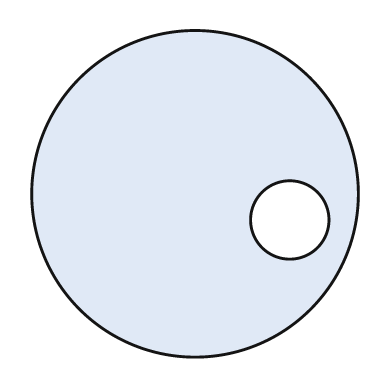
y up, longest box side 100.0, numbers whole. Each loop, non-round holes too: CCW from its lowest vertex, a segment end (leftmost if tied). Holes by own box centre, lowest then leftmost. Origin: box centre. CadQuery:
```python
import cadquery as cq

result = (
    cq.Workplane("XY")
    .moveTo(0.0, 0.0)
    .circle(50.0)
    .moveTo(29.0, -8.0)
    .circle(12.0)
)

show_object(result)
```